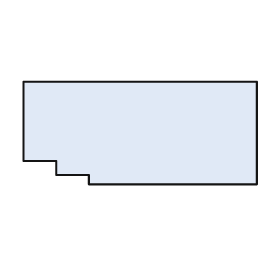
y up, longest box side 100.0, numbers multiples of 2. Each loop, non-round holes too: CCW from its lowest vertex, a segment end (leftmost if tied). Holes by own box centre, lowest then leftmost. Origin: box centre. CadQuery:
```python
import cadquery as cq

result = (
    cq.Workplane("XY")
    .moveTo(-22.0, -22.0)
    .lineTo(50.0, -22.0)
    .lineTo(50.0, 22.0)
    .lineTo(-50.0, 22.0)
    .lineTo(-50.0, -12.0)
    .lineTo(-36.0, -12.0)
    .lineTo(-36.0, -18.0)
    .lineTo(-22.0, -18.0)
    .close()
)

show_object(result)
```